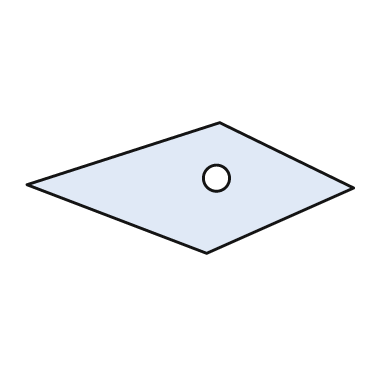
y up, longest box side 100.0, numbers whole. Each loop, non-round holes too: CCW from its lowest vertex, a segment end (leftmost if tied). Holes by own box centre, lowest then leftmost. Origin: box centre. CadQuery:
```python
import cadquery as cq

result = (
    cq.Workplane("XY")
    .moveTo(5.0, -20.0)
    .lineTo(50.0, 0.0)
    .lineTo(9.0, 20.0)
    .lineTo(-50.0, 1.0)
    .close()
    .moveTo(8.0, 3.0)
    .circle(4.0)
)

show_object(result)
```